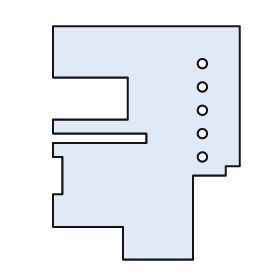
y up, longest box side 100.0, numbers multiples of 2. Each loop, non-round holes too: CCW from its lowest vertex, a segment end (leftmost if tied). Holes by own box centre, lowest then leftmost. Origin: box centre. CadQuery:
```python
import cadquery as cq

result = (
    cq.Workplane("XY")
    .moveTo(-10.0, -50.0)
    .lineTo(20.0, -50.0)
    .lineTo(20.0, -14.0)
    .lineTo(34.0, -14.0)
    .lineTo(34.0, -10.0)
    .lineTo(40.0, -10.0)
    .lineTo(40.0, 50.0)
    .lineTo(-40.0, 50.0)
    .lineTo(-40.0, 28.0)
    .lineTo(-8.0, 28.0)
    .lineTo(-8.0, 10.0)
    .lineTo(-40.0, 10.0)
    .lineTo(-40.0, 4.0)
    .lineTo(0.0, 4.0)
    .lineTo(0.0, 0.0)
    .lineTo(-40.0, 0.0)
    .lineTo(-40.0, -6.0)
    .lineTo(-36.0, -6.0)
    .lineTo(-36.0, -22.0)
    .lineTo(-40.0, -22.0)
    .lineTo(-40.0, -36.0)
    .lineTo(-10.0, -36.0)
    .close()
    .moveTo(24.0, -6.0)
    .circle(2.0)
    .moveTo(24.0, 4.0)
    .circle(2.0)
    .moveTo(24.0, 14.0)
    .circle(2.0)
    .moveTo(24.0, 24.0)
    .circle(2.0)
    .moveTo(24.0, 34.0)
    .circle(2.0)
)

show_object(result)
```